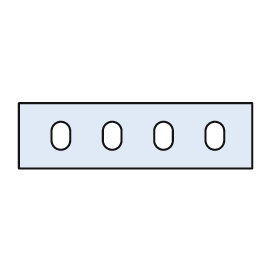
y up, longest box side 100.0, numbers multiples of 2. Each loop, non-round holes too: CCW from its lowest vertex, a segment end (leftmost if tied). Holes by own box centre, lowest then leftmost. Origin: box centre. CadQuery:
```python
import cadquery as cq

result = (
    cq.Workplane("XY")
    .moveTo(-50.0, -14.0)
    .lineTo(50.0, -14.0)
    .lineTo(50.0, 14.0)
    .lineTo(-50.0, 14.0)
    .close()
    .moveTo(-36.0, -2.0)
    .threePointArc((-32.0, -6.0), (-28.0, -2.0))
    .lineTo(-28.0, 2.0)
    .threePointArc((-32.0, 6.0), (-36.0, 2.0))
    .close()
    .moveTo(-14.0, -2.0)
    .threePointArc((-10.0, -6.0), (-6.0, -2.0))
    .lineTo(-6.0, 2.0)
    .threePointArc((-10.0, 6.0), (-14.0, 2.0))
    .close()
    .moveTo(8.0, -2.0)
    .threePointArc((12.0, -6.0), (16.0, -2.0))
    .lineTo(16.0, 2.0)
    .threePointArc((12.0, 6.0), (8.0, 2.0))
    .close()
    .moveTo(30.0, -2.0)
    .threePointArc((34.0, -6.0), (38.0, -2.0))
    .lineTo(38.0, 2.0)
    .threePointArc((34.0, 6.0), (30.0, 2.0))
    .close()
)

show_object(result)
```